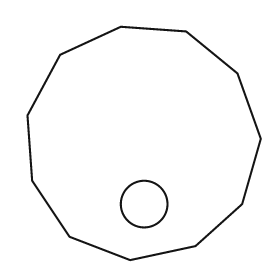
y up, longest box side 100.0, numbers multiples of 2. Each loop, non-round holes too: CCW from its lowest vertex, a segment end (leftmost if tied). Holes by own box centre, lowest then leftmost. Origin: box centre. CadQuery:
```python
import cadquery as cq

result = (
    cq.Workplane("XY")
    .moveTo(-6.0, -50.0)
    .lineTo(22.0, -44.0)
    .lineTo(42.0, -26.0)
    .lineTo(50.0, 2.0)
    .lineTo(40.0, 30.0)
    .lineTo(18.0, 48.0)
    .lineTo(-10.0, 50.0)
    .lineTo(-36.0, 38.0)
    .lineTo(-50.0, 12.0)
    .lineTo(-48.0, -16.0)
    .lineTo(-32.0, -40.0)
    .close()
    .moveTo(0.0, -26.0)
    .circle(10.0)
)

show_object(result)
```